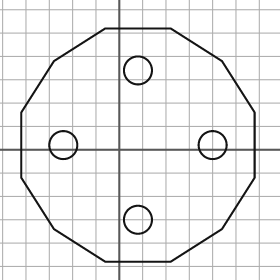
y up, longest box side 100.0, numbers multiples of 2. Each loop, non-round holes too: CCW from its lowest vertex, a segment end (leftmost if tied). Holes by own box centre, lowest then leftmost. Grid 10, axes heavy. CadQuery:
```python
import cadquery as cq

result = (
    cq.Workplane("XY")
    .moveTo(-6.0, -48.0)
    .lineTo(22.0, -48.0)
    .lineTo(44.0, -34.0)
    .lineTo(58.0, -12.0)
    .lineTo(58.0, 16.0)
    .lineTo(44.0, 38.0)
    .lineTo(22.0, 52.0)
    .lineTo(-6.0, 52.0)
    .lineTo(-28.0, 38.0)
    .lineTo(-42.0, 16.0)
    .lineTo(-42.0, -12.0)
    .lineTo(-28.0, -34.0)
    .close()
    .moveTo(8.0, -30.0)
    .circle(6.0)
    .moveTo(-24.0, 2.0)
    .circle(6.0)
    .moveTo(40.0, 2.0)
    .circle(6.0)
    .moveTo(8.0, 34.0)
    .circle(6.0)
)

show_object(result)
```